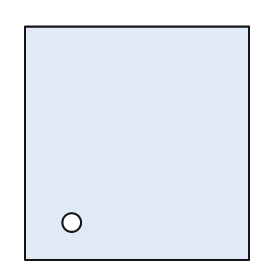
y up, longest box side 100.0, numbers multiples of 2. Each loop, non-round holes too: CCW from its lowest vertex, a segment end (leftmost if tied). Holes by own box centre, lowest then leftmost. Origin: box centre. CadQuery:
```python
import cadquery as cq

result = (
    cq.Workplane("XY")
    .moveTo(-48.0, -50.0)
    .lineTo(48.0, -50.0)
    .lineTo(48.0, 50.0)
    .lineTo(-48.0, 50.0)
    .close()
    .moveTo(-28.0, -34.0)
    .circle(4.0)
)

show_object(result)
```